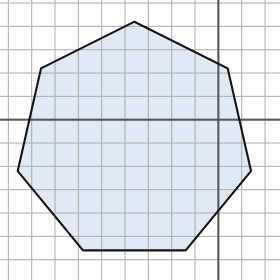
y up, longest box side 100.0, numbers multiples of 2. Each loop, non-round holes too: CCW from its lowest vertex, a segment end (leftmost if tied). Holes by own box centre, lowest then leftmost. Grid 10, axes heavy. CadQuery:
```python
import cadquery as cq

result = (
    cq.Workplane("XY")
    .moveTo(-58.0, -56.0)
    .lineTo(-14.0, -56.0)
    .lineTo(14.0, -22.0)
    .lineTo(4.0, 22.0)
    .lineTo(-36.0, 42.0)
    .lineTo(-76.0, 22.0)
    .lineTo(-86.0, -22.0)
    .close()
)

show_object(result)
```